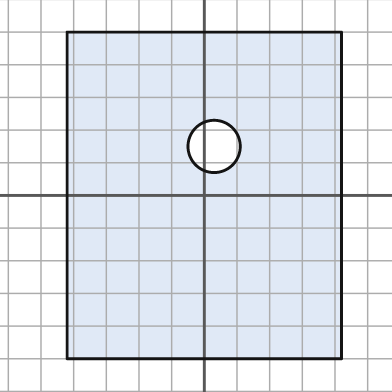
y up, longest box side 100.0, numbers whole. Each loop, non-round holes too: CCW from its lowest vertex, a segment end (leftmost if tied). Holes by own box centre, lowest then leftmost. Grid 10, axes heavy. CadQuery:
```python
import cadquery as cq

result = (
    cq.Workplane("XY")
    .moveTo(-42.0, -50.0)
    .lineTo(42.0, -50.0)
    .lineTo(42.0, 50.0)
    .lineTo(-42.0, 50.0)
    .close()
    .moveTo(3.0, 15.0)
    .circle(8.0)
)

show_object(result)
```